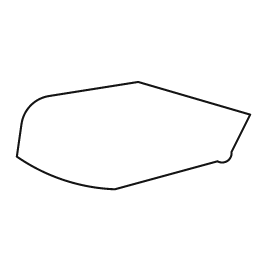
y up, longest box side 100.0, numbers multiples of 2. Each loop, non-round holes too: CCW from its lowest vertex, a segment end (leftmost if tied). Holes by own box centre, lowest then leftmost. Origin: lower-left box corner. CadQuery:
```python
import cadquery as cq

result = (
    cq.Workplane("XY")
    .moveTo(42.0, 0.0)
    .lineTo(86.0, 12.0)
    .threePointArc((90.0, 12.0), (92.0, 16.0))
    .lineTo(100.0, 32.0)
    .lineTo(52.0, 46.0)
    .lineTo(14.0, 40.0)
    .threePointArc((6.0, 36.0), (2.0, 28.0))
    .lineTo(0.0, 14.0)
    .threePointArc((20.0, 4.0), (42.0, 0.0))
    .close()
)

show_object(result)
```